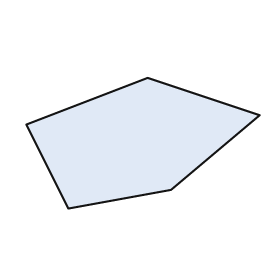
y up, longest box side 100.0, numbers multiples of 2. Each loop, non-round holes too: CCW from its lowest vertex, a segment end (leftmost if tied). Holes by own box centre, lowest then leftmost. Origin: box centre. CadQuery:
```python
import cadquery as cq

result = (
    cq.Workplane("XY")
    .moveTo(-32.0, -28.0)
    .lineTo(12.0, -20.0)
    .lineTo(50.0, 12.0)
    .lineTo(2.0, 28.0)
    .lineTo(-50.0, 8.0)
    .close()
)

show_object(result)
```